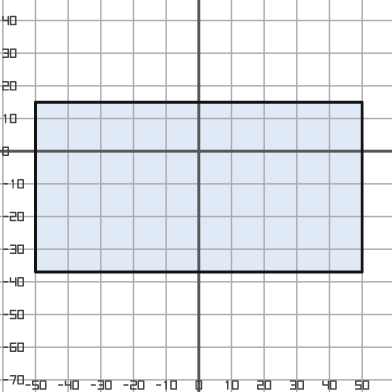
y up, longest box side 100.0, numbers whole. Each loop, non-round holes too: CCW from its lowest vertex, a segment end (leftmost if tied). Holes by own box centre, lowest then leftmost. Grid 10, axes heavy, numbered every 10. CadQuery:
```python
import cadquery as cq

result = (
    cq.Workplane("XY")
    .moveTo(-50.0, -37.0)
    .lineTo(50.0, -37.0)
    .lineTo(50.0, 15.0)
    .lineTo(-50.0, 15.0)
    .close()
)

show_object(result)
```